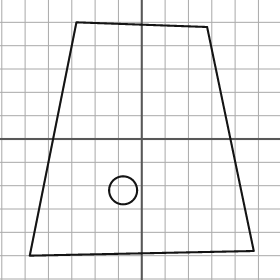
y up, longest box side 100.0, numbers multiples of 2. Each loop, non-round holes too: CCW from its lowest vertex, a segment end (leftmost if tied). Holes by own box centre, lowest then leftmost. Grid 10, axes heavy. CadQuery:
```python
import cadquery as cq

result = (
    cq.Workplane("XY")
    .moveTo(-48.0, -50.0)
    .lineTo(48.0, -48.0)
    .lineTo(28.0, 48.0)
    .lineTo(-28.0, 50.0)
    .close()
    .moveTo(-8.0, -22.0)
    .circle(6.0)
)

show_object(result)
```